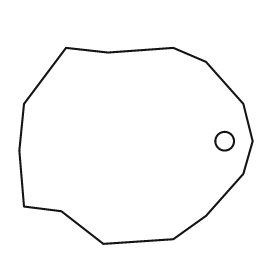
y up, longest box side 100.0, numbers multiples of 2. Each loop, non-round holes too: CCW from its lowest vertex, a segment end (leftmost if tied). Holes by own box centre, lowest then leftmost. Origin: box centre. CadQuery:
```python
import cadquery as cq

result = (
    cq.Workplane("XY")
    .moveTo(-14.0, -42.0)
    .lineTo(16.0, -40.0)
    .lineTo(30.0, -30.0)
    .lineTo(46.0, -12.0)
    .lineTo(50.0, 2.0)
    .lineTo(46.0, 18.0)
    .lineTo(30.0, 36.0)
    .lineTo(16.0, 42.0)
    .lineTo(-12.0, 40.0)
    .lineTo(-30.0, 42.0)
    .lineTo(-48.0, 18.0)
    .lineTo(-50.0, -2.0)
    .lineTo(-48.0, -26.0)
    .lineTo(-32.0, -28.0)
    .close()
    .moveTo(38.0, 2.0)
    .circle(4.0)
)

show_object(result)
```